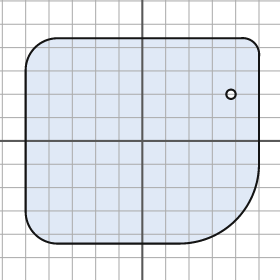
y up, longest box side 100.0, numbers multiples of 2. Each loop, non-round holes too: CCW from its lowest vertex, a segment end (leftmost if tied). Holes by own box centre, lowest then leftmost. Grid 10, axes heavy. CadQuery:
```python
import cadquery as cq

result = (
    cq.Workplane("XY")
    .moveTo(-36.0, -44.0)
    .lineTo(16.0, -44.0)
    .threePointArc((40.0, -34.0), (50.0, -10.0))
    .lineTo(50.0, 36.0)
    .threePointArc((48.0, 42.0), (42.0, 44.0))
    .lineTo(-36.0, 44.0)
    .threePointArc((-46.0, 40.0), (-50.0, 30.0))
    .lineTo(-50.0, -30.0)
    .threePointArc((-46.0, -40.0), (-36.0, -44.0))
    .close()
    .moveTo(38.0, 20.0)
    .circle(2.0)
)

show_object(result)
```